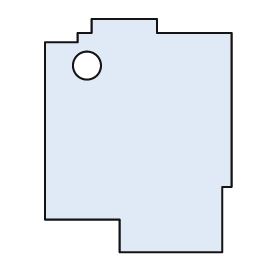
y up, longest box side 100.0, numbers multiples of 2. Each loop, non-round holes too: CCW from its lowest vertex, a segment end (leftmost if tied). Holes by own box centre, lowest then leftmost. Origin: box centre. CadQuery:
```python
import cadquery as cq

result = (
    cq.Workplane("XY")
    .moveTo(-8.0, -50.0)
    .lineTo(36.0, -50.0)
    .lineTo(36.0, -22.0)
    .lineTo(40.0, -22.0)
    .lineTo(40.0, 44.0)
    .lineTo(8.0, 44.0)
    .lineTo(8.0, 50.0)
    .lineTo(-20.0, 50.0)
    .lineTo(-20.0, 44.0)
    .lineTo(-26.0, 44.0)
    .lineTo(-26.0, 40.0)
    .lineTo(-40.0, 40.0)
    .lineTo(-40.0, -36.0)
    .lineTo(-8.0, -36.0)
    .close()
    .moveTo(-22.0, 30.0)
    .circle(6.0)
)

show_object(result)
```